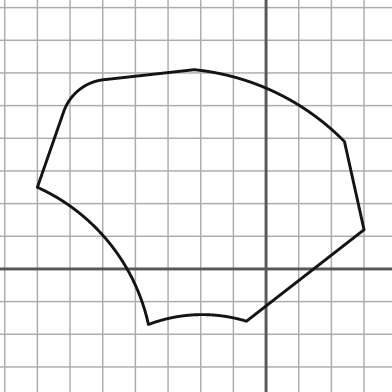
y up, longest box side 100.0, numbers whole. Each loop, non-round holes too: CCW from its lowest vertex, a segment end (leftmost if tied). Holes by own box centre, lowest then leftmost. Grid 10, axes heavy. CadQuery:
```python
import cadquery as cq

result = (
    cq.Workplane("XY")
    .moveTo(-36.0, -17.0)
    .threePointArc((-21.0, -14.0), (-6.0, -16.0))
    .lineTo(30.0, 12.0)
    .lineTo(24.0, 39.0)
    .threePointArc((3.0, 54.0), (-22.0, 61.0))
    .lineTo(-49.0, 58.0)
    .threePointArc((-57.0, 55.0), (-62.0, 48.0))
    .lineTo(-70.0, 25.0)
    .threePointArc((-48.0, 8.0), (-36.0, -17.0))
    .close()
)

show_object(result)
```